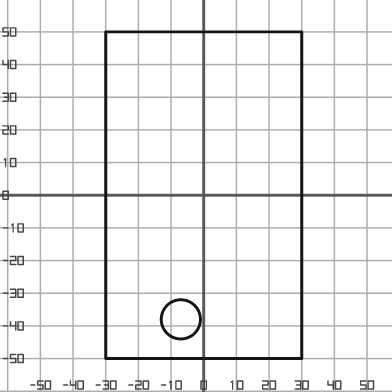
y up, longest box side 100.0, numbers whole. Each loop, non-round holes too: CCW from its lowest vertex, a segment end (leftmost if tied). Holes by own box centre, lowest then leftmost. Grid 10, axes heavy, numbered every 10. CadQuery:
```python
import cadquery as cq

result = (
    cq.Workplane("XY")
    .moveTo(-30.0, -50.0)
    .lineTo(30.0, -50.0)
    .lineTo(30.0, 50.0)
    .lineTo(-30.0, 50.0)
    .close()
    .moveTo(-7.0, -38.0)
    .circle(6.0)
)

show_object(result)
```